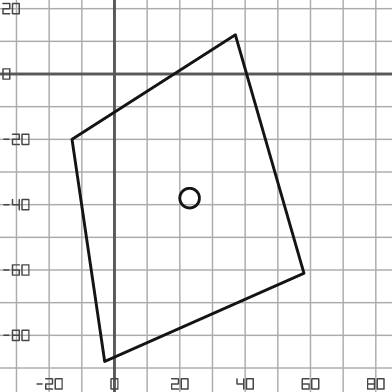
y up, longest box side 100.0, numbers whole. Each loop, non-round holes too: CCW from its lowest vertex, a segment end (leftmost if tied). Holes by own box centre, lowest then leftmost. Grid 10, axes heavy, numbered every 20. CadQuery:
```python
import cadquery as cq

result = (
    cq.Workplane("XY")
    .moveTo(-3.0, -88.0)
    .lineTo(58.0, -61.0)
    .lineTo(37.0, 12.0)
    .lineTo(-13.0, -20.0)
    .close()
    .moveTo(23.0, -38.0)
    .circle(3.0)
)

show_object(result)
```